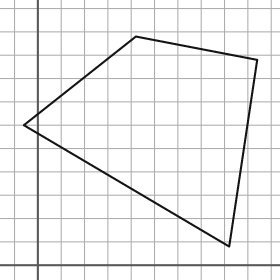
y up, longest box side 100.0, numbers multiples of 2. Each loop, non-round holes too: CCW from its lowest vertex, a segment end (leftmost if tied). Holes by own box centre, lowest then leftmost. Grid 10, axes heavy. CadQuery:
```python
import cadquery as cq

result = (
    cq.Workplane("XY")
    .moveTo(82.0, 8.0)
    .lineTo(94.0, 88.0)
    .lineTo(42.0, 98.0)
    .lineTo(-6.0, 60.0)
    .close()
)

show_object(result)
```